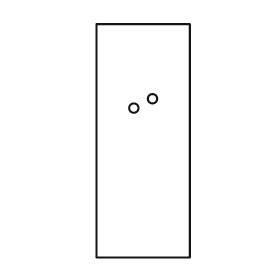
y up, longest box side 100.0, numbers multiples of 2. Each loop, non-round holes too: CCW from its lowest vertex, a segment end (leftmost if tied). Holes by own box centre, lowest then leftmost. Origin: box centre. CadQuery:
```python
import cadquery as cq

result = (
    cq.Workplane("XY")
    .moveTo(-20.0, -50.0)
    .lineTo(20.0, -50.0)
    .lineTo(20.0, 50.0)
    .lineTo(-20.0, 50.0)
    .close()
    .moveTo(-4.0, 14.0)
    .circle(2.0)
    .moveTo(4.0, 18.0)
    .circle(2.0)
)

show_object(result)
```